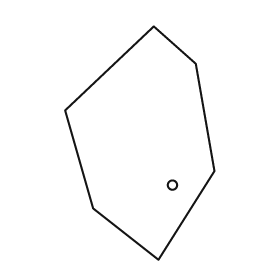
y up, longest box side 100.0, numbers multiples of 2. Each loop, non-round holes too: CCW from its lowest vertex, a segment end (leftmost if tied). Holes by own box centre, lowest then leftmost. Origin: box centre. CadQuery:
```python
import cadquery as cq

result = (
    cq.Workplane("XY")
    .moveTo(8.0, -50.0)
    .lineTo(32.0, -12.0)
    .lineTo(24.0, 34.0)
    .lineTo(6.0, 50.0)
    .lineTo(-32.0, 14.0)
    .lineTo(-20.0, -28.0)
    .close()
    .moveTo(14.0, -18.0)
    .circle(2.0)
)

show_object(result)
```